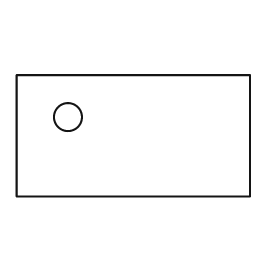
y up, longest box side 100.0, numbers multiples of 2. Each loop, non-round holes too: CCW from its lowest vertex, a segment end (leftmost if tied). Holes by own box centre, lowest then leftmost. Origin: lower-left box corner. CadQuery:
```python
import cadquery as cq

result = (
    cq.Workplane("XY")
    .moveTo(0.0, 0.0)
    .lineTo(100.0, 0.0)
    .lineTo(100.0, 52.0)
    .lineTo(0.0, 52.0)
    .close()
    .moveTo(22.0, 34.0)
    .circle(6.0)
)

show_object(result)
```